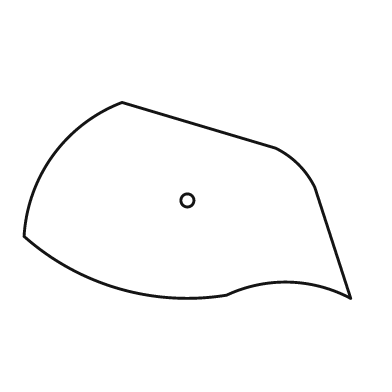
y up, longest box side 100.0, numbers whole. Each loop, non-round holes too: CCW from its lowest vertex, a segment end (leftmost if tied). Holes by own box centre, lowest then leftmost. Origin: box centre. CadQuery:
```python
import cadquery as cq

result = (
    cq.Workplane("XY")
    .moveTo(50.0, -30.0)
    .lineTo(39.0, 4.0)
    .threePointArc((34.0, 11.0), (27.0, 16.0))
    .lineTo(-20.0, 30.0)
    .threePointArc((-41.0, 14.0), (-50.0, -11.0))
    .threePointArc((-21.0, -27.0), (12.0, -29.0))
    .threePointArc((31.0, -25.0), (50.0, -30.0))
    .close()
    .moveTo(0.0, 0.0)
    .circle(2.0)
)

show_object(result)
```